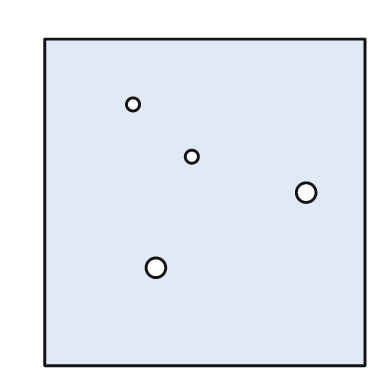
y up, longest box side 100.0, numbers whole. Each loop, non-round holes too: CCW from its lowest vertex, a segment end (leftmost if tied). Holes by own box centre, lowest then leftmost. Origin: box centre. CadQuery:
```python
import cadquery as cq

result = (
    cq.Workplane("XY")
    .moveTo(-49.0, -50.0)
    .lineTo(49.0, -50.0)
    .lineTo(49.0, 50.0)
    .lineTo(-49.0, 50.0)
    .close()
    .moveTo(-15.0, -20.0)
    .circle(3.0)
    .moveTo(31.0, 3.0)
    .circle(3.0)
    .moveTo(-4.0, 14.0)
    .circle(2.0)
    .moveTo(-22.0, 30.0)
    .circle(2.0)
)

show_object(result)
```